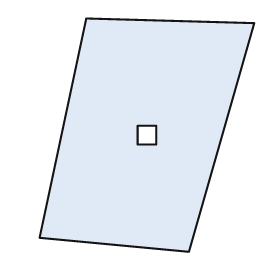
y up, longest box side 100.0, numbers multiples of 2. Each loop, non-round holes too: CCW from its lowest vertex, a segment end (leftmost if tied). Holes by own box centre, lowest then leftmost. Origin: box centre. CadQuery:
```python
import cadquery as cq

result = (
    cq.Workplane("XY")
    .moveTo(18.0, -50.0)
    .lineTo(46.0, 48.0)
    .lineTo(-26.0, 50.0)
    .lineTo(-46.0, -44.0)
    .close()
    .moveTo(-4.0, -4.0)
    .lineTo(4.0, -4.0)
    .lineTo(4.0, 4.0)
    .lineTo(-4.0, 4.0)
    .close()
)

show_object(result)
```